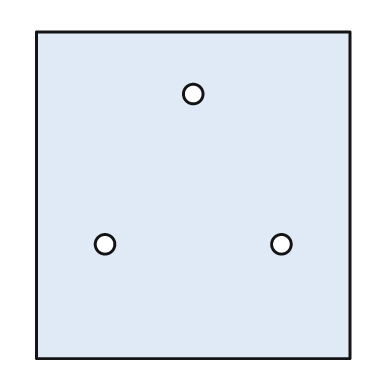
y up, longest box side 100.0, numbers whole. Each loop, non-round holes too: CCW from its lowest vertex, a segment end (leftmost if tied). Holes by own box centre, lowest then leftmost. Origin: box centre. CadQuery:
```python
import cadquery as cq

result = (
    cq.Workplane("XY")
    .moveTo(-48.0, -50.0)
    .lineTo(48.0, -50.0)
    .lineTo(48.0, 50.0)
    .lineTo(-48.0, 50.0)
    .close()
    .moveTo(-27.0, -15.0)
    .circle(3.0)
    .moveTo(27.0, -15.0)
    .circle(3.0)
    .moveTo(0.0, 31.0)
    .circle(3.0)
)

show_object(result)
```